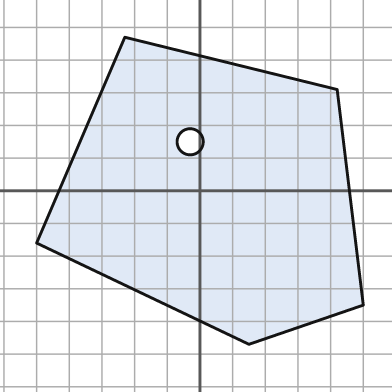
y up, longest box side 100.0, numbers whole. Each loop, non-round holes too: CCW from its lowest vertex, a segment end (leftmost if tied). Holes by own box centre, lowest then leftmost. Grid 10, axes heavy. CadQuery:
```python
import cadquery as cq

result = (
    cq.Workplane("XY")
    .moveTo(15.0, -47.0)
    .lineTo(50.0, -35.0)
    .lineTo(42.0, 31.0)
    .lineTo(-23.0, 47.0)
    .lineTo(-50.0, -16.0)
    .close()
    .moveTo(-3.0, 15.0)
    .circle(4.0)
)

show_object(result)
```